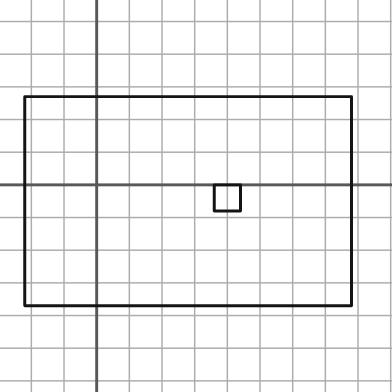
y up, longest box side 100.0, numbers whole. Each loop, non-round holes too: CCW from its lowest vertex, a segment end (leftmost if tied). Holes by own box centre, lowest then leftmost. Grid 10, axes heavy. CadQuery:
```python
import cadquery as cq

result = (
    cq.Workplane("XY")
    .moveTo(-22.0, -37.0)
    .lineTo(78.0, -37.0)
    .lineTo(78.0, 27.0)
    .lineTo(-22.0, 27.0)
    .close()
    .moveTo(36.0, -8.0)
    .lineTo(44.0, -8.0)
    .lineTo(44.0, 0.0)
    .lineTo(36.0, 0.0)
    .close()
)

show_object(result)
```